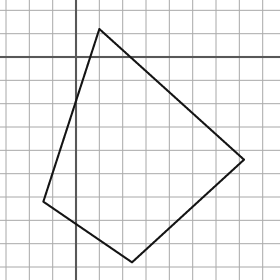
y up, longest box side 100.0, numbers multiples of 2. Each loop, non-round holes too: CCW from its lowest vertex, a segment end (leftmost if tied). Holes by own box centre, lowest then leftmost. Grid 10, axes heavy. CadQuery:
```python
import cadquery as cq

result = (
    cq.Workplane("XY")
    .moveTo(24.0, -88.0)
    .lineTo(72.0, -44.0)
    .lineTo(10.0, 12.0)
    .lineTo(-14.0, -62.0)
    .close()
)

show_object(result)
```